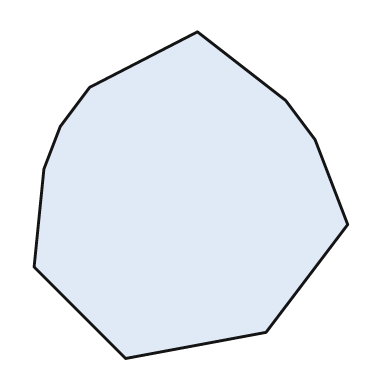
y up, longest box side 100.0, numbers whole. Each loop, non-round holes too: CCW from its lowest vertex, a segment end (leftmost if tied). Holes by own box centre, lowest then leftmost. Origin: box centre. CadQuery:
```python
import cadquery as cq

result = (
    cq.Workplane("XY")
    .moveTo(-20.0, -50.0)
    .lineTo(23.0, -42.0)
    .lineTo(48.0, -9.0)
    .lineTo(38.0, 17.0)
    .lineTo(29.0, 29.0)
    .lineTo(2.0, 50.0)
    .lineTo(-31.0, 33.0)
    .lineTo(-40.0, 21.0)
    .lineTo(-45.0, 8.0)
    .lineTo(-48.0, -22.0)
    .close()
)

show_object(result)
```